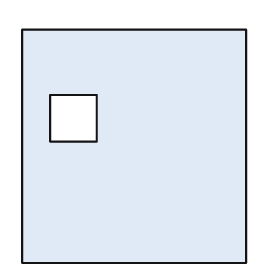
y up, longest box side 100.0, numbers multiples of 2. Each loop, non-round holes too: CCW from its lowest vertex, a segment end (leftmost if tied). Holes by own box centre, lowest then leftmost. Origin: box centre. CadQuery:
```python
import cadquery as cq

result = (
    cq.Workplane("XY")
    .moveTo(-48.0, -50.0)
    .lineTo(48.0, -50.0)
    .lineTo(48.0, 50.0)
    .lineTo(-48.0, 50.0)
    .close()
    .moveTo(-36.0, 2.0)
    .lineTo(-16.0, 2.0)
    .lineTo(-16.0, 22.0)
    .lineTo(-36.0, 22.0)
    .close()
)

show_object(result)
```